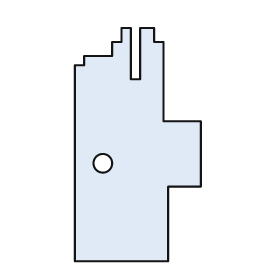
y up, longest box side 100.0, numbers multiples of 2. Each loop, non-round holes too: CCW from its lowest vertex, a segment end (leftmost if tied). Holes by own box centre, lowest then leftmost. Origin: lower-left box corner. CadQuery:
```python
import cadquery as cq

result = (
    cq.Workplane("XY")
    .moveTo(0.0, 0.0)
    .lineTo(40.0, 0.0)
    .lineTo(40.0, 32.0)
    .lineTo(54.0, 32.0)
    .lineTo(54.0, 60.0)
    .lineTo(38.0, 60.0)
    .lineTo(38.0, 94.0)
    .lineTo(34.0, 94.0)
    .lineTo(34.0, 100.0)
    .lineTo(28.0, 100.0)
    .lineTo(28.0, 78.0)
    .lineTo(24.0, 78.0)
    .lineTo(24.0, 100.0)
    .lineTo(20.0, 100.0)
    .lineTo(20.0, 94.0)
    .lineTo(16.0, 94.0)
    .lineTo(16.0, 88.0)
    .lineTo(4.0, 88.0)
    .lineTo(4.0, 84.0)
    .lineTo(0.0, 84.0)
    .close()
    .moveTo(12.0, 42.0)
    .circle(4.0)
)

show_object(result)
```